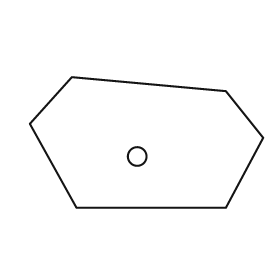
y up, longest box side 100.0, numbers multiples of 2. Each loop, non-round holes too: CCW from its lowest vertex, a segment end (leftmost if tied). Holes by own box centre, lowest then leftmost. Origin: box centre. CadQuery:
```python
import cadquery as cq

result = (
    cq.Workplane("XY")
    .moveTo(-30.0, -28.0)
    .lineTo(34.0, -28.0)
    .lineTo(50.0, 2.0)
    .lineTo(34.0, 22.0)
    .lineTo(-32.0, 28.0)
    .lineTo(-50.0, 8.0)
    .close()
    .moveTo(-4.0, -6.0)
    .circle(4.0)
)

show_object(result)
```